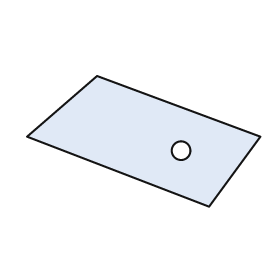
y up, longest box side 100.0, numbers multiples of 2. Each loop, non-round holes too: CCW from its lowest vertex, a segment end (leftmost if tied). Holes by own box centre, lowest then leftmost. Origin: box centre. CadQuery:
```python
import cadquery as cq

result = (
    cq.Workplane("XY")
    .moveTo(28.0, -28.0)
    .lineTo(50.0, 2.0)
    .lineTo(-20.0, 28.0)
    .lineTo(-50.0, 2.0)
    .close()
    .moveTo(16.0, -4.0)
    .circle(4.0)
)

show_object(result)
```